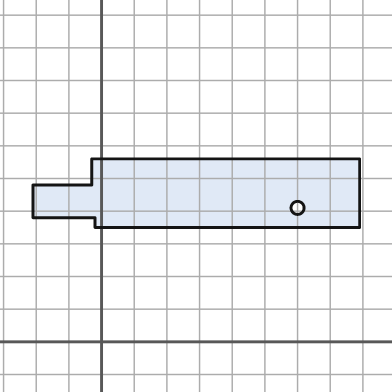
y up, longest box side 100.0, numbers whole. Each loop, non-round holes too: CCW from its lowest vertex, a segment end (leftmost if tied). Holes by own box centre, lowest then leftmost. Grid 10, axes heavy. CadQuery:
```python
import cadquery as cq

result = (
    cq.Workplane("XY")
    .moveTo(-2.0, 35.0)
    .lineTo(79.0, 35.0)
    .lineTo(79.0, 56.0)
    .lineTo(-3.0, 56.0)
    .lineTo(-3.0, 48.0)
    .lineTo(-21.0, 48.0)
    .lineTo(-21.0, 38.0)
    .lineTo(-2.0, 38.0)
    .close()
    .moveTo(60.0, 41.0)
    .circle(2.0)
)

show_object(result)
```